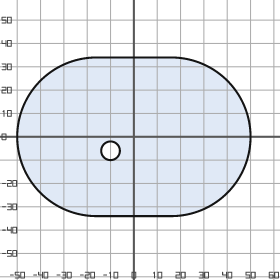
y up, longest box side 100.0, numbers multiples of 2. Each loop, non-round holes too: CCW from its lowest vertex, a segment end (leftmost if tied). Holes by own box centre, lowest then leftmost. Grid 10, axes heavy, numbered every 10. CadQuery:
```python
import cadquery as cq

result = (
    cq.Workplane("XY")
    .moveTo(-16.0, -34.0)
    .lineTo(16.0, -34.0)
    .threePointArc((50.0, 0.0), (16.0, 34.0))
    .lineTo(-16.0, 34.0)
    .threePointArc((-50.0, 0.0), (-16.0, -34.0))
    .close()
    .moveTo(-10.0, -6.0)
    .circle(4.0)
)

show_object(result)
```